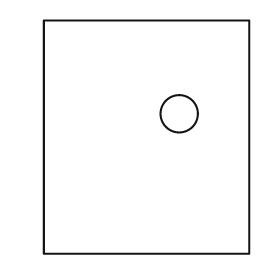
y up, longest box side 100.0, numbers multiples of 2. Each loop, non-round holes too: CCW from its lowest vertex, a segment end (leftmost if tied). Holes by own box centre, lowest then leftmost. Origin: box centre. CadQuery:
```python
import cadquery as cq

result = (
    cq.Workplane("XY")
    .moveTo(-44.0, -50.0)
    .lineTo(44.0, -50.0)
    .lineTo(44.0, 50.0)
    .lineTo(-44.0, 50.0)
    .close()
    .moveTo(14.0, 10.0)
    .circle(8.0)
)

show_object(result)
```